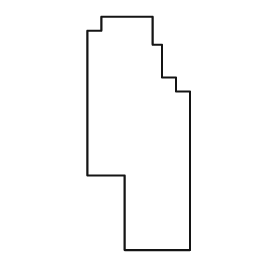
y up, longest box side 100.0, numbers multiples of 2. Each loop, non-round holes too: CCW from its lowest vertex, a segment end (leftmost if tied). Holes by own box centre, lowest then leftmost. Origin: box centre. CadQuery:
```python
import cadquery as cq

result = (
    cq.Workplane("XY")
    .moveTo(-6.0, -50.0)
    .lineTo(22.0, -50.0)
    .lineTo(22.0, 18.0)
    .lineTo(16.0, 18.0)
    .lineTo(16.0, 24.0)
    .lineTo(10.0, 24.0)
    .lineTo(10.0, 38.0)
    .lineTo(6.0, 38.0)
    .lineTo(6.0, 50.0)
    .lineTo(-16.0, 50.0)
    .lineTo(-16.0, 44.0)
    .lineTo(-22.0, 44.0)
    .lineTo(-22.0, -18.0)
    .lineTo(-6.0, -18.0)
    .close()
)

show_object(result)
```